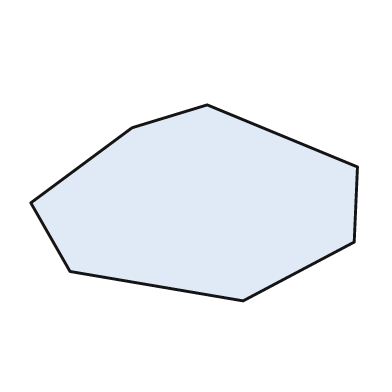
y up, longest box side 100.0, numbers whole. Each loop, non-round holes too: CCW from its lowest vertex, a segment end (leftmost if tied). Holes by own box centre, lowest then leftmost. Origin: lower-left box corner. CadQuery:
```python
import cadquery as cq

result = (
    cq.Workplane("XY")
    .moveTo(65.0, 0.0)
    .lineTo(99.0, 18.0)
    .lineTo(100.0, 41.0)
    .lineTo(54.0, 60.0)
    .lineTo(31.0, 53.0)
    .lineTo(0.0, 30.0)
    .lineTo(12.0, 9.0)
    .close()
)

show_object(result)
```